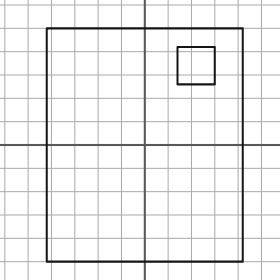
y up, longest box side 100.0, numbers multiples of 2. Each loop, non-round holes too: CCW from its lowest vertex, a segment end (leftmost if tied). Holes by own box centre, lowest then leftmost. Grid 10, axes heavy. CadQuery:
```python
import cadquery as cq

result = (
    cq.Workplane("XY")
    .moveTo(-42.0, -50.0)
    .lineTo(42.0, -50.0)
    .lineTo(42.0, 50.0)
    .lineTo(-42.0, 50.0)
    .close()
    .moveTo(14.0, 26.0)
    .lineTo(30.0, 26.0)
    .lineTo(30.0, 42.0)
    .lineTo(14.0, 42.0)
    .close()
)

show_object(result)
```